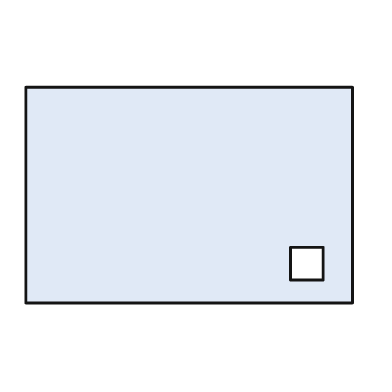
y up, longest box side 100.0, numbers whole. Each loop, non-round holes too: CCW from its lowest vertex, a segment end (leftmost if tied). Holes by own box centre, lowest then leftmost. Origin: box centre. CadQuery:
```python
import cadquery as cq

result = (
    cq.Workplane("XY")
    .moveTo(-50.0, -33.0)
    .lineTo(50.0, -33.0)
    .lineTo(50.0, 33.0)
    .lineTo(-50.0, 33.0)
    .close()
    .moveTo(31.0, -26.0)
    .lineTo(41.0, -26.0)
    .lineTo(41.0, -16.0)
    .lineTo(31.0, -16.0)
    .close()
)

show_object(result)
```